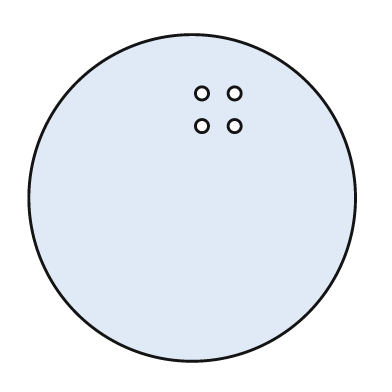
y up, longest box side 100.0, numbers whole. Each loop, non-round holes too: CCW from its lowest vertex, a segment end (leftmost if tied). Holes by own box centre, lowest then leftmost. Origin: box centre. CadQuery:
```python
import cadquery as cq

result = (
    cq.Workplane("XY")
    .moveTo(0.0, 0.0)
    .circle(50.0)
    .moveTo(3.0, 22.0)
    .circle(2.0)
    .moveTo(13.0, 22.0)
    .circle(2.0)
    .moveTo(3.0, 32.0)
    .circle(2.0)
    .moveTo(13.0, 32.0)
    .circle(2.0)
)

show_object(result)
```